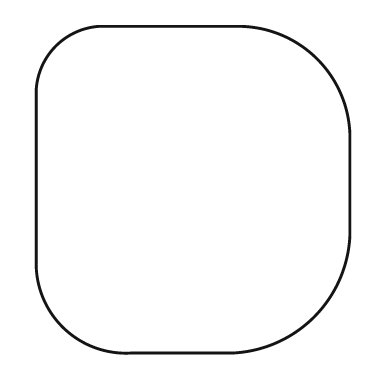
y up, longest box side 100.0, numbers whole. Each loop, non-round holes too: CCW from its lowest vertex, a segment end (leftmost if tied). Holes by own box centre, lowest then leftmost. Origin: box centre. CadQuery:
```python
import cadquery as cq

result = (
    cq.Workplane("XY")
    .moveTo(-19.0, -50.0)
    .lineTo(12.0, -50.0)
    .threePointArc((37.0, -39.0), (48.0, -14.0))
    .lineTo(48.0, 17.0)
    .threePointArc((38.0, 40.0), (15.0, 50.0))
    .lineTo(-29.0, 50.0)
    .threePointArc((-42.0, 44.0), (-48.0, 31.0))
    .lineTo(-48.0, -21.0)
    .threePointArc((-40.0, -42.0), (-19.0, -50.0))
    .close()
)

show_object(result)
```